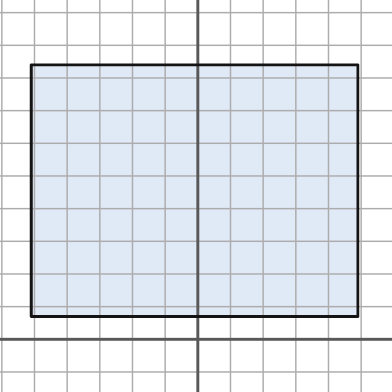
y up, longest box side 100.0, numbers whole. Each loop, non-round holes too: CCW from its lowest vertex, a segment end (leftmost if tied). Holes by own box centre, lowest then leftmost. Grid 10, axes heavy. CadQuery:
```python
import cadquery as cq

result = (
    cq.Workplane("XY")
    .moveTo(-51.0, 7.0)
    .lineTo(49.0, 7.0)
    .lineTo(49.0, 84.0)
    .lineTo(-51.0, 84.0)
    .close()
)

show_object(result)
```